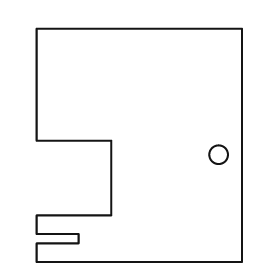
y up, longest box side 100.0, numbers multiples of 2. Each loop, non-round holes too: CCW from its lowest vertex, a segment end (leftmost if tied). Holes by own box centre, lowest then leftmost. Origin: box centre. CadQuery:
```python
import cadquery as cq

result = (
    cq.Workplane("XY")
    .moveTo(-44.0, -50.0)
    .lineTo(44.0, -50.0)
    .lineTo(44.0, 50.0)
    .lineTo(-44.0, 50.0)
    .lineTo(-44.0, 2.0)
    .lineTo(-12.0, 2.0)
    .lineTo(-12.0, -30.0)
    .lineTo(-44.0, -30.0)
    .lineTo(-44.0, -38.0)
    .lineTo(-26.0, -38.0)
    .lineTo(-26.0, -42.0)
    .lineTo(-44.0, -42.0)
    .close()
    .moveTo(34.0, -4.0)
    .circle(4.0)
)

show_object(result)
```